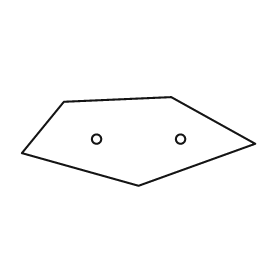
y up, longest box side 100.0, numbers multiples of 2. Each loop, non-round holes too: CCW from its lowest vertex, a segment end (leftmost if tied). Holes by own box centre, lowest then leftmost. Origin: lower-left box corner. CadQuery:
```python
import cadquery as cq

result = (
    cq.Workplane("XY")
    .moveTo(50.0, 0.0)
    .lineTo(100.0, 18.0)
    .lineTo(64.0, 38.0)
    .lineTo(18.0, 36.0)
    .lineTo(0.0, 14.0)
    .close()
    .moveTo(32.0, 20.0)
    .circle(2.0)
    .moveTo(68.0, 20.0)
    .circle(2.0)
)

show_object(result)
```